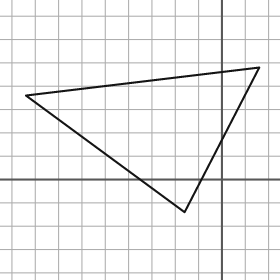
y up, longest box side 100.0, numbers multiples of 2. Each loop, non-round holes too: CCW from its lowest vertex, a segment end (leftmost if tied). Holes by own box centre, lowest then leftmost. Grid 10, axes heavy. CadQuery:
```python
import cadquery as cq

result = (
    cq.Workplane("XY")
    .moveTo(-16.0, -14.0)
    .lineTo(16.0, 48.0)
    .lineTo(-84.0, 36.0)
    .close()
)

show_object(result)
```